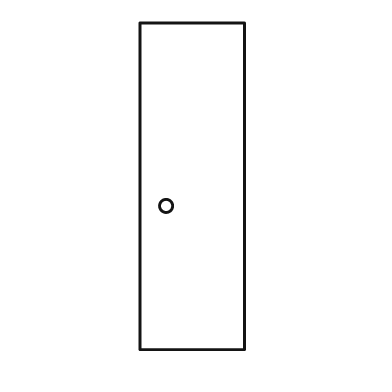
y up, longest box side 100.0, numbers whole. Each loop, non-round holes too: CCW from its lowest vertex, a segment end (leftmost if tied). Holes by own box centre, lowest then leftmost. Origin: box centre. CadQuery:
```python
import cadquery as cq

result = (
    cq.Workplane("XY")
    .moveTo(-16.0, -50.0)
    .lineTo(16.0, -50.0)
    .lineTo(16.0, 50.0)
    .lineTo(-16.0, 50.0)
    .close()
    .moveTo(-8.0, -6.0)
    .circle(2.0)
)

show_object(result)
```